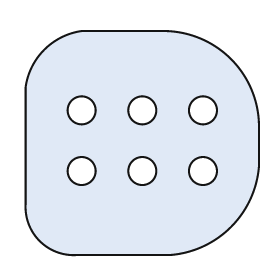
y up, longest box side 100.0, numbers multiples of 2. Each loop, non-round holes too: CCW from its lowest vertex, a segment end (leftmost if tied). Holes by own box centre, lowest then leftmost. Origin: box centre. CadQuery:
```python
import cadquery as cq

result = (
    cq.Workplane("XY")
    .moveTo(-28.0, -48.0)
    .lineTo(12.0, -48.0)
    .threePointArc((38.0, -36.0), (50.0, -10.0))
    .lineTo(50.0, 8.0)
    .threePointArc((38.0, 36.0), (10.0, 48.0))
    .lineTo(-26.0, 48.0)
    .threePointArc((-42.0, 40.0), (-50.0, 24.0))
    .lineTo(-50.0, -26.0)
    .threePointArc((-44.0, -42.0), (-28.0, -48.0))
    .close()
    .moveTo(-26.0, -12.0)
    .circle(6.0)
    .moveTo(0.0, -12.0)
    .circle(6.0)
    .moveTo(26.0, -12.0)
    .circle(6.0)
    .moveTo(-26.0, 14.0)
    .circle(6.0)
    .moveTo(0.0, 14.0)
    .circle(6.0)
    .moveTo(26.0, 14.0)
    .circle(6.0)
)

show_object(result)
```